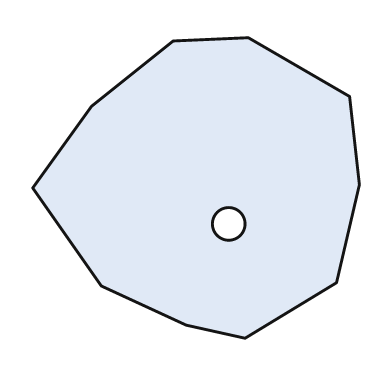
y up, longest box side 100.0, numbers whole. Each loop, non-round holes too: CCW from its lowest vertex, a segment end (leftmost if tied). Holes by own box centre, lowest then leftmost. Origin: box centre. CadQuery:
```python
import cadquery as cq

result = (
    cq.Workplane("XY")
    .moveTo(15.0, -46.0)
    .lineTo(43.0, -29.0)
    .lineTo(50.0, 1.0)
    .lineTo(47.0, 28.0)
    .lineTo(16.0, 46.0)
    .lineTo(-7.0, 45.0)
    .lineTo(-32.0, 25.0)
    .lineTo(-50.0, 0.0)
    .lineTo(-29.0, -30.0)
    .lineTo(-3.0, -42.0)
    .close()
    .moveTo(10.0, -11.0)
    .circle(5.0)
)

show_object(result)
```